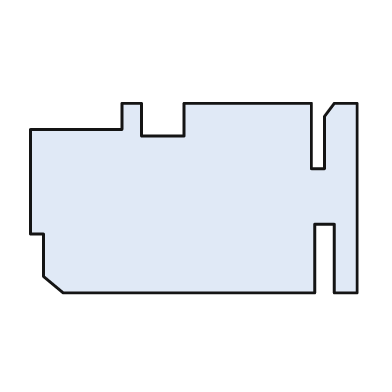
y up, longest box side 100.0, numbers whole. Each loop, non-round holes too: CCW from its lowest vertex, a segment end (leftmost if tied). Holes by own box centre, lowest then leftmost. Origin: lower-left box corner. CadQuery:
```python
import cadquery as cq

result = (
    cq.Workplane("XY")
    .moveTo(10.0, 0.0)
    .lineTo(87.0, 0.0)
    .lineTo(87.0, 21.0)
    .lineTo(93.0, 21.0)
    .lineTo(93.0, 0.0)
    .lineTo(100.0, 0.0)
    .lineTo(100.0, 58.0)
    .lineTo(93.0, 58.0)
    .lineTo(90.0, 54.0)
    .lineTo(90.0, 38.0)
    .lineTo(86.0, 38.0)
    .lineTo(86.0, 58.0)
    .lineTo(47.0, 58.0)
    .lineTo(47.0, 48.0)
    .lineTo(34.0, 48.0)
    .lineTo(34.0, 58.0)
    .lineTo(28.0, 58.0)
    .lineTo(28.0, 50.0)
    .lineTo(0.0, 50.0)
    .lineTo(0.0, 18.0)
    .lineTo(4.0, 18.0)
    .lineTo(4.0, 5.0)
    .close()
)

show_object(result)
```